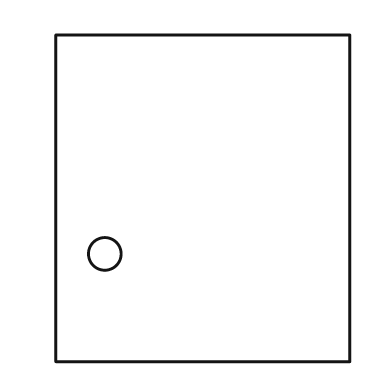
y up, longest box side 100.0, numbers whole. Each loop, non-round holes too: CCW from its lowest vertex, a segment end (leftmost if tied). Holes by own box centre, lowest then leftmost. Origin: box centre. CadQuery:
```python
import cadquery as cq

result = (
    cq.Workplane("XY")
    .moveTo(-45.0, -50.0)
    .lineTo(45.0, -50.0)
    .lineTo(45.0, 50.0)
    .lineTo(-45.0, 50.0)
    .close()
    .moveTo(-30.0, -17.0)
    .circle(5.0)
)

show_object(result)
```